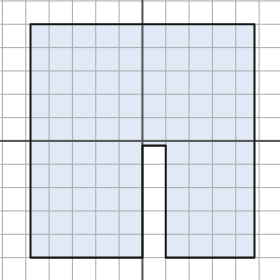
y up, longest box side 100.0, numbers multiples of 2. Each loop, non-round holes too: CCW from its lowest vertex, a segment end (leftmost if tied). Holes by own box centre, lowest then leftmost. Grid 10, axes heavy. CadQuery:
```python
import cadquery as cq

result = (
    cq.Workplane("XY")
    .moveTo(-48.0, -50.0)
    .lineTo(0.0, -50.0)
    .lineTo(0.0, -2.0)
    .lineTo(10.0, -2.0)
    .lineTo(10.0, -50.0)
    .lineTo(48.0, -50.0)
    .lineTo(48.0, 50.0)
    .lineTo(-48.0, 50.0)
    .close()
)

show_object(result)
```